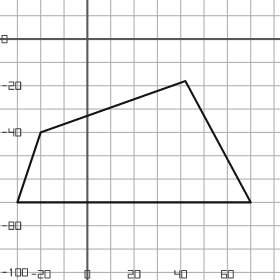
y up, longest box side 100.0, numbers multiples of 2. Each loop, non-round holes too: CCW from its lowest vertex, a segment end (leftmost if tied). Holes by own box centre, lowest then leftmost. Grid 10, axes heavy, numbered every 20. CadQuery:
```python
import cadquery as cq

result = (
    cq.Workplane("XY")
    .moveTo(-30.0, -70.0)
    .lineTo(70.0, -70.0)
    .lineTo(42.0, -18.0)
    .lineTo(-20.0, -40.0)
    .close()
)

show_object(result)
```